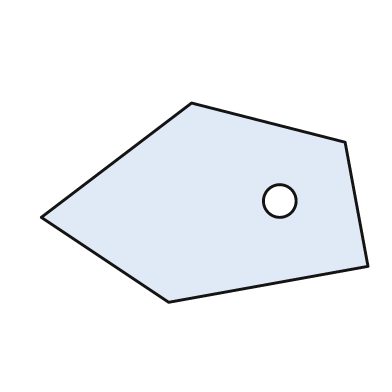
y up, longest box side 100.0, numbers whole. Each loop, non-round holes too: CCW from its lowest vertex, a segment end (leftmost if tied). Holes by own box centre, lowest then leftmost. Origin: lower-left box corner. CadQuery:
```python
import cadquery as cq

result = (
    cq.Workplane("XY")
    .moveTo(39.0, 0.0)
    .lineTo(100.0, 11.0)
    .lineTo(93.0, 49.0)
    .lineTo(46.0, 61.0)
    .lineTo(0.0, 26.0)
    .close()
    .moveTo(73.0, 31.0)
    .circle(5.0)
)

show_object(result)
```